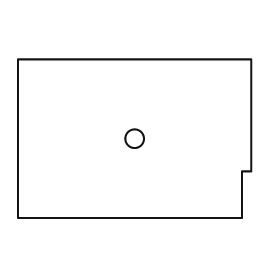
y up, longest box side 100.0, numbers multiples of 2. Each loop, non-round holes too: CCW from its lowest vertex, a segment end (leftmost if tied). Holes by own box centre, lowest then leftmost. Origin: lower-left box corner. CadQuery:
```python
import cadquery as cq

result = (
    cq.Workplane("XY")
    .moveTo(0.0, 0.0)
    .lineTo(96.0, 0.0)
    .lineTo(96.0, 20.0)
    .lineTo(100.0, 20.0)
    .lineTo(100.0, 68.0)
    .lineTo(0.0, 68.0)
    .close()
    .moveTo(50.0, 34.0)
    .circle(4.0)
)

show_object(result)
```